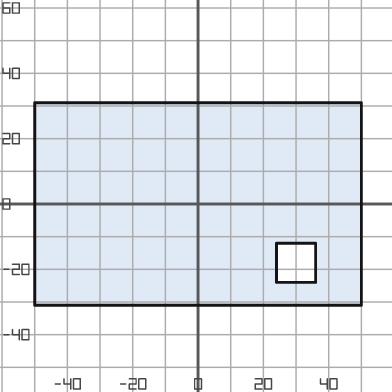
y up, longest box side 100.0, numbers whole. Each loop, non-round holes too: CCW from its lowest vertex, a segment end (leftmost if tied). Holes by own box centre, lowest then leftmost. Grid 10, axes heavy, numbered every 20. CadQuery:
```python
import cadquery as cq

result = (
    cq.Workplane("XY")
    .moveTo(-50.0, -31.0)
    .lineTo(50.0, -31.0)
    .lineTo(50.0, 31.0)
    .lineTo(-50.0, 31.0)
    .close()
    .moveTo(24.0, -24.0)
    .lineTo(36.0, -24.0)
    .lineTo(36.0, -12.0)
    .lineTo(24.0, -12.0)
    .close()
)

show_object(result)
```